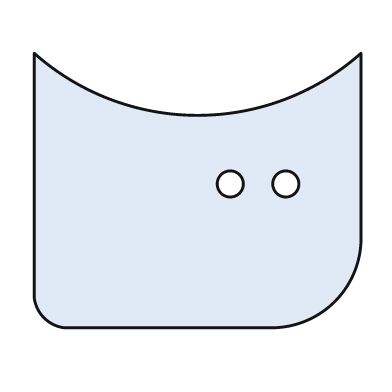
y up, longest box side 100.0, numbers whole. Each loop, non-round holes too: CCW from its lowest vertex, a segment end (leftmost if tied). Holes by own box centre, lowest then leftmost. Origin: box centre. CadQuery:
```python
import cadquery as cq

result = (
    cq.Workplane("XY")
    .moveTo(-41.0, -42.0)
    .lineTo(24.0, -42.0)
    .threePointArc((42.0, -34.0), (50.0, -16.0))
    .lineTo(50.0, 42.0)
    .threePointArc((0.0, 23.0), (-50.0, 42.0))
    .lineTo(-50.0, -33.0)
    .threePointArc((-47.0, -39.0), (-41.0, -42.0))
    .close()
    .moveTo(10.0, 2.0)
    .circle(4.0)
    .moveTo(27.0, 2.0)
    .circle(4.0)
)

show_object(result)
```